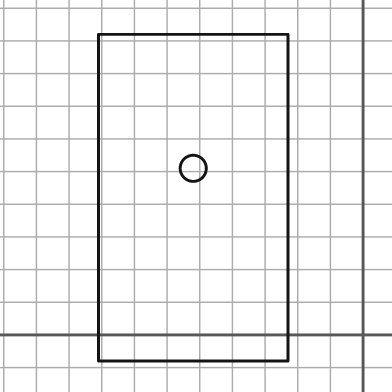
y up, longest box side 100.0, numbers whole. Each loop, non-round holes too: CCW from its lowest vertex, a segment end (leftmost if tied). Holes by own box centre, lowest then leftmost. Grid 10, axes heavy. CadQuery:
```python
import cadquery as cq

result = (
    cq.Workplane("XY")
    .moveTo(-81.0, -8.0)
    .lineTo(-23.0, -8.0)
    .lineTo(-23.0, 92.0)
    .lineTo(-81.0, 92.0)
    .close()
    .moveTo(-52.0, 51.0)
    .circle(4.0)
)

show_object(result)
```